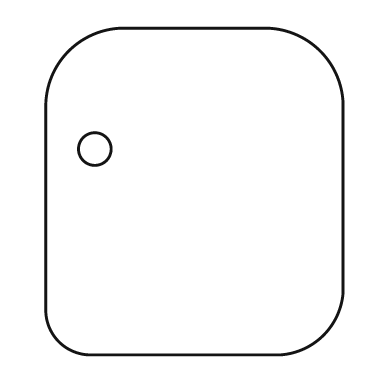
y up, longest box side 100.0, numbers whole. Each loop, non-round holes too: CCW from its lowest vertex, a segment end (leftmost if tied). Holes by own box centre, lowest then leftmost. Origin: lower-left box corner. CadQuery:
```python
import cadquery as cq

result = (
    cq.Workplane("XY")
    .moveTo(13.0, 0.0)
    .lineTo(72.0, 0.0)
    .threePointArc((85.0, 6.0), (91.0, 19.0))
    .lineTo(91.0, 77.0)
    .threePointArc((84.0, 93.0), (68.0, 100.0))
    .lineTo(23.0, 100.0)
    .threePointArc((7.0, 93.0), (0.0, 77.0))
    .lineTo(0.0, 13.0)
    .threePointArc((4.0, 4.0), (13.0, 0.0))
    .close()
    .moveTo(15.0, 63.0)
    .circle(5.0)
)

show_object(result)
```